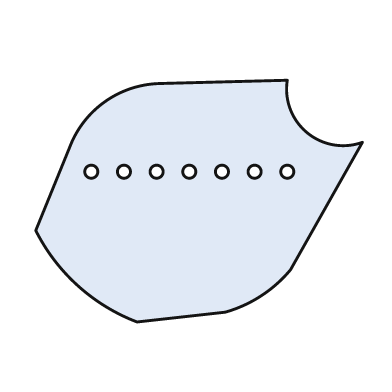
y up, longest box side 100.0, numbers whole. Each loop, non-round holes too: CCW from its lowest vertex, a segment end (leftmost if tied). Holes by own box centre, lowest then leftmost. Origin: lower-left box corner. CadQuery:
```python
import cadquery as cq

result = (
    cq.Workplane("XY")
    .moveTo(31.0, 0.0)
    .lineTo(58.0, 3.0)
    .threePointArc((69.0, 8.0), (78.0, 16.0))
    .lineTo(100.0, 55.0)
    .threePointArc((83.0, 58.0), (77.0, 74.0))
    .lineTo(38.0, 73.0)
    .threePointArc((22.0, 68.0), (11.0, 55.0))
    .lineTo(0.0, 28.0)
    .threePointArc((13.0, 11.0), (31.0, 0.0))
    .close()
    .moveTo(17.0, 46.0)
    .circle(2.0)
    .moveTo(27.0, 46.0)
    .circle(2.0)
    .moveTo(37.0, 46.0)
    .circle(2.0)
    .moveTo(47.0, 46.0)
    .circle(2.0)
    .moveTo(57.0, 46.0)
    .circle(2.0)
    .moveTo(67.0, 46.0)
    .circle(2.0)
    .moveTo(77.0, 46.0)
    .circle(2.0)
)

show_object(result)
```